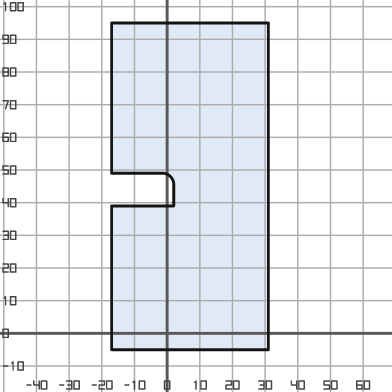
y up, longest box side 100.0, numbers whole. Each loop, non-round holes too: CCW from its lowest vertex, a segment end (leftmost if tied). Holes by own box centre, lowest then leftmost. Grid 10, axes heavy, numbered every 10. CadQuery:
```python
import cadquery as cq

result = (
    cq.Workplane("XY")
    .moveTo(-17.0, -5.0)
    .lineTo(31.0, -5.0)
    .lineTo(31.0, 95.0)
    .lineTo(-17.0, 95.0)
    .lineTo(-17.0, 49.0)
    .lineTo(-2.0, 49.0)
    .threePointArc((1.0, 48.0), (2.0, 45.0))
    .lineTo(2.0, 39.0)
    .lineTo(-17.0, 39.0)
    .close()
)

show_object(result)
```